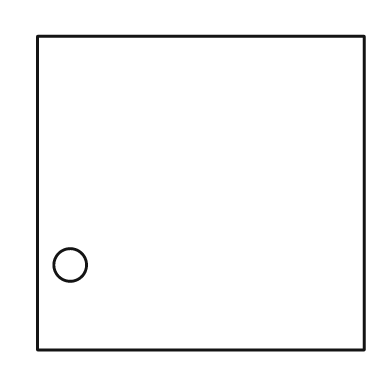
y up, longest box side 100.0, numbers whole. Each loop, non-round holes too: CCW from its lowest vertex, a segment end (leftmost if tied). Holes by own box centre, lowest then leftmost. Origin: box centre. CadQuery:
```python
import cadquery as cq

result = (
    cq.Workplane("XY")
    .moveTo(-50.0, -48.0)
    .lineTo(50.0, -48.0)
    .lineTo(50.0, 48.0)
    .lineTo(-50.0, 48.0)
    .close()
    .moveTo(-40.0, -22.0)
    .circle(5.0)
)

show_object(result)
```